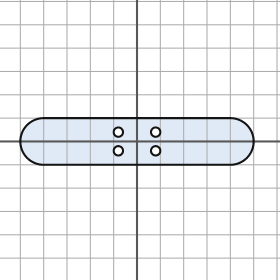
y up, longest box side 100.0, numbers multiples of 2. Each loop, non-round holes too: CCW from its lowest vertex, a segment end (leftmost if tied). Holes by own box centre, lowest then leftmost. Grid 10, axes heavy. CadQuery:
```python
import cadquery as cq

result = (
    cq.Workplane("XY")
    .moveTo(-40.0, -10.0)
    .lineTo(40.0, -10.0)
    .threePointArc((50.0, 0.0), (40.0, 10.0))
    .lineTo(-40.0, 10.0)
    .threePointArc((-50.0, 0.0), (-40.0, -10.0))
    .close()
    .moveTo(-8.0, -4.0)
    .circle(2.0)
    .moveTo(8.0, -4.0)
    .circle(2.0)
    .moveTo(-8.0, 4.0)
    .circle(2.0)
    .moveTo(8.0, 4.0)
    .circle(2.0)
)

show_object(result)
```